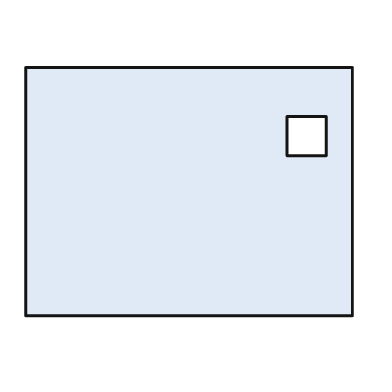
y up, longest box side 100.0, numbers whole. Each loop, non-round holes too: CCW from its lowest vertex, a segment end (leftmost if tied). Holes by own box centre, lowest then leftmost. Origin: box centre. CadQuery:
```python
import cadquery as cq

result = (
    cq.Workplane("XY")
    .moveTo(-50.0, -38.0)
    .lineTo(50.0, -38.0)
    .lineTo(50.0, 38.0)
    .lineTo(-50.0, 38.0)
    .close()
    .moveTo(30.0, 11.0)
    .lineTo(42.0, 11.0)
    .lineTo(42.0, 23.0)
    .lineTo(30.0, 23.0)
    .close()
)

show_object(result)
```